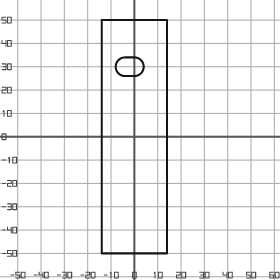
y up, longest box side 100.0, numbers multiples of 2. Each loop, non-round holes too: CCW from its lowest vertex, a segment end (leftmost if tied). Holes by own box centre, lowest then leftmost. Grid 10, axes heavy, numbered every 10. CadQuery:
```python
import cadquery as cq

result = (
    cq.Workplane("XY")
    .moveTo(-14.0, -50.0)
    .lineTo(14.0, -50.0)
    .lineTo(14.0, 50.0)
    .lineTo(-14.0, 50.0)
    .close()
    .moveTo(-4.0, 26.0)
    .lineTo(0.0, 26.0)
    .threePointArc((4.0, 30.0), (0.0, 34.0))
    .lineTo(-4.0, 34.0)
    .threePointArc((-8.0, 30.0), (-4.0, 26.0))
    .close()
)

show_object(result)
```